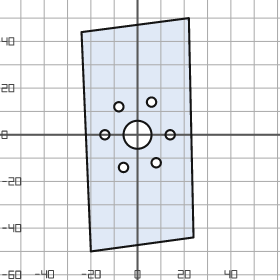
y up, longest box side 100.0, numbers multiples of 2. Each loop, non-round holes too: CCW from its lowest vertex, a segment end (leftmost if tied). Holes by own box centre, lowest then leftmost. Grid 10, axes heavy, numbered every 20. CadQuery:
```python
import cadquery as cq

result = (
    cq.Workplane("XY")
    .moveTo(-20.0, -50.0)
    .lineTo(24.0, -44.0)
    .lineTo(22.0, 50.0)
    .lineTo(-24.0, 44.0)
    .close()
    .moveTo(-6.0, -14.0)
    .circle(2.0)
    .moveTo(8.0, -12.0)
    .circle(2.0)
    .moveTo(-14.0, 0.0)
    .circle(2.0)
    .moveTo(0.0, 0.0)
    .circle(6.0)
    .moveTo(14.0, 0.0)
    .circle(2.0)
    .moveTo(-8.0, 12.0)
    .circle(2.0)
    .moveTo(6.0, 14.0)
    .circle(2.0)
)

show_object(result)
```